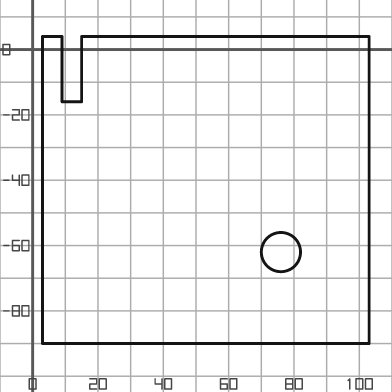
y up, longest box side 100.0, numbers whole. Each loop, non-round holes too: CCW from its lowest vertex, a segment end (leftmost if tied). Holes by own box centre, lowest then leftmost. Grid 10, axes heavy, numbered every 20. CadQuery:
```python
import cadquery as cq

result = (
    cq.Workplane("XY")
    .moveTo(3.0, -90.0)
    .lineTo(103.0, -90.0)
    .lineTo(103.0, 4.0)
    .lineTo(15.0, 4.0)
    .lineTo(15.0, -16.0)
    .lineTo(9.0, -16.0)
    .lineTo(9.0, 4.0)
    .lineTo(3.0, 4.0)
    .close()
    .moveTo(76.0, -62.0)
    .circle(6.0)
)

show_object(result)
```